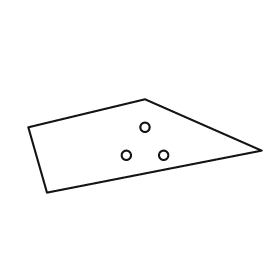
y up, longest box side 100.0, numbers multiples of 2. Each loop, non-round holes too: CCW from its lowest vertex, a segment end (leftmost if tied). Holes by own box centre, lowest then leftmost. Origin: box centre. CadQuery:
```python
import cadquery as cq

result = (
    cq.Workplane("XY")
    .moveTo(-42.0, -20.0)
    .lineTo(50.0, -2.0)
    .lineTo(0.0, 20.0)
    .lineTo(-50.0, 8.0)
    .close()
    .moveTo(-8.0, -4.0)
    .circle(2.0)
    .moveTo(8.0, -4.0)
    .circle(2.0)
    .moveTo(0.0, 8.0)
    .circle(2.0)
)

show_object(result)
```